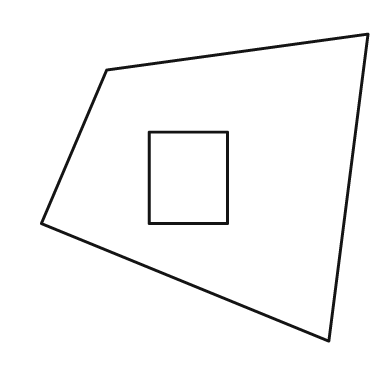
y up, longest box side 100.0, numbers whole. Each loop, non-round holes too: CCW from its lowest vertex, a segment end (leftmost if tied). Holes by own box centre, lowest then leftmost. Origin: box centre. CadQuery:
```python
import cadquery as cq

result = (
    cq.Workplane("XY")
    .moveTo(38.0, -47.0)
    .lineTo(50.0, 47.0)
    .lineTo(-30.0, 36.0)
    .lineTo(-50.0, -11.0)
    .close()
    .moveTo(-17.0, -11.0)
    .lineTo(7.0, -11.0)
    .lineTo(7.0, 17.0)
    .lineTo(-17.0, 17.0)
    .close()
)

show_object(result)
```